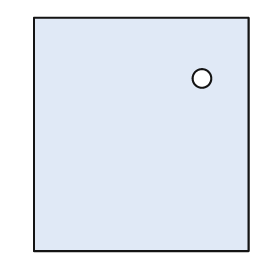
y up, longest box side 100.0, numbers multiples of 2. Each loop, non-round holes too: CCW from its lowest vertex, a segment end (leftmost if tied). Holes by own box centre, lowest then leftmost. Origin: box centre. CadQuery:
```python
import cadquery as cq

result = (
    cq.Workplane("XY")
    .moveTo(-46.0, -50.0)
    .lineTo(46.0, -50.0)
    .lineTo(46.0, 50.0)
    .lineTo(-46.0, 50.0)
    .close()
    .moveTo(26.0, 24.0)
    .circle(4.0)
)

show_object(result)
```